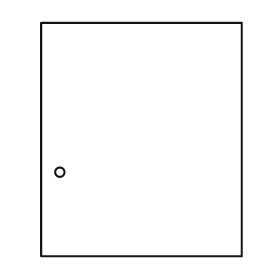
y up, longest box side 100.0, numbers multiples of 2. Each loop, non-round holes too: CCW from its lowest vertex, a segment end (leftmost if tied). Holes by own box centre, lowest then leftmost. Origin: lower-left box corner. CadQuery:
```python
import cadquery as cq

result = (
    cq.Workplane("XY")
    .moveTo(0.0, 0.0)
    .lineTo(86.0, 0.0)
    .lineTo(86.0, 100.0)
    .lineTo(0.0, 100.0)
    .close()
    .moveTo(8.0, 36.0)
    .circle(2.0)
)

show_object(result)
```